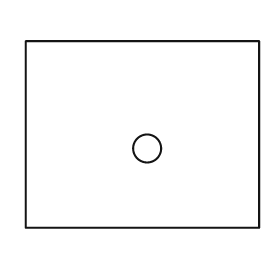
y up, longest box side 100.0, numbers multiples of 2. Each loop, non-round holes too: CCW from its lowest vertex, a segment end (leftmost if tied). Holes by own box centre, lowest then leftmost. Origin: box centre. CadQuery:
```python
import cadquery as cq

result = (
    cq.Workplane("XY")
    .moveTo(-50.0, -40.0)
    .lineTo(50.0, -40.0)
    .lineTo(50.0, 40.0)
    .lineTo(-50.0, 40.0)
    .close()
    .moveTo(2.0, -6.0)
    .circle(6.0)
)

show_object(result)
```